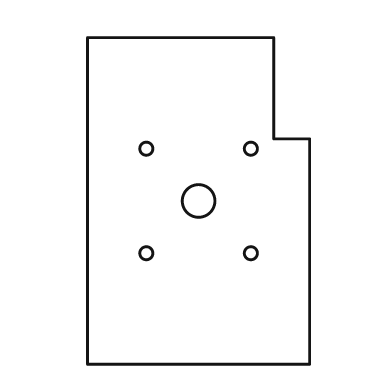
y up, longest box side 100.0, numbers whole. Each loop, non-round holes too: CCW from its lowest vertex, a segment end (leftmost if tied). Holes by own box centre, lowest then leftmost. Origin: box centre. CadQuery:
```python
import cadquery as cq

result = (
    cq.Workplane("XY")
    .moveTo(-34.0, -50.0)
    .lineTo(34.0, -50.0)
    .lineTo(34.0, 19.0)
    .lineTo(23.0, 19.0)
    .lineTo(23.0, 50.0)
    .lineTo(-34.0, 50.0)
    .close()
    .moveTo(-16.0, -16.0)
    .circle(2.0)
    .moveTo(16.0, -16.0)
    .circle(2.0)
    .moveTo(0.0, 0.0)
    .circle(5.0)
    .moveTo(-16.0, 16.0)
    .circle(2.0)
    .moveTo(16.0, 16.0)
    .circle(2.0)
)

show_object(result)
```